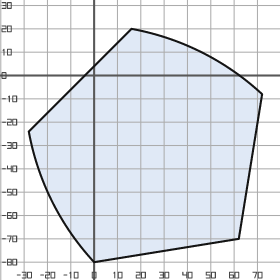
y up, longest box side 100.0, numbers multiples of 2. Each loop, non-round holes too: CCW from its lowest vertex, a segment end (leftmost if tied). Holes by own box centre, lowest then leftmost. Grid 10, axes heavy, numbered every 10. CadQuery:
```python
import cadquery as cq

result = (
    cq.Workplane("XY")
    .moveTo(0.0, -80.0)
    .lineTo(62.0, -70.0)
    .lineTo(72.0, -8.0)
    .threePointArc((46.0, 10.0), (16.0, 20.0))
    .lineTo(-28.0, -24.0)
    .threePointArc((-18.0, -54.0), (0.0, -80.0))
    .close()
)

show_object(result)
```